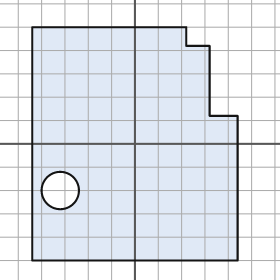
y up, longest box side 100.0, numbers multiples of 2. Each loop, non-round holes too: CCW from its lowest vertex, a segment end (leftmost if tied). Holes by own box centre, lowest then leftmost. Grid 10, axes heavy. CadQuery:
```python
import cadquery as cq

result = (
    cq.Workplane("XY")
    .moveTo(-44.0, -50.0)
    .lineTo(44.0, -50.0)
    .lineTo(44.0, 12.0)
    .lineTo(32.0, 12.0)
    .lineTo(32.0, 42.0)
    .lineTo(22.0, 42.0)
    .lineTo(22.0, 50.0)
    .lineTo(-44.0, 50.0)
    .close()
    .moveTo(-32.0, -20.0)
    .circle(8.0)
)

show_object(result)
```